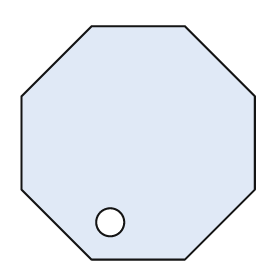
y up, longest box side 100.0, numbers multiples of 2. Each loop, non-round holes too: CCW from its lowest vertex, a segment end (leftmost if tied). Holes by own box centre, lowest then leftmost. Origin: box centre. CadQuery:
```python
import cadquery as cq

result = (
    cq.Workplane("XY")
    .moveTo(-20.0, -50.0)
    .lineTo(20.0, -50.0)
    .lineTo(50.0, -20.0)
    .lineTo(50.0, 20.0)
    .lineTo(20.0, 50.0)
    .lineTo(-20.0, 50.0)
    .lineTo(-50.0, 20.0)
    .lineTo(-50.0, -20.0)
    .close()
    .moveTo(-12.0, -34.0)
    .circle(6.0)
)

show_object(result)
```